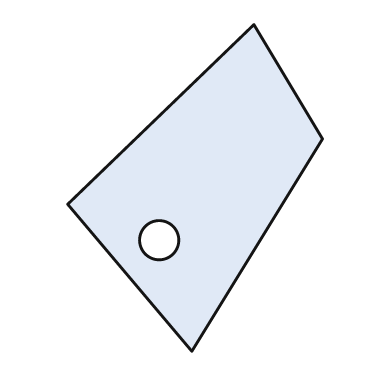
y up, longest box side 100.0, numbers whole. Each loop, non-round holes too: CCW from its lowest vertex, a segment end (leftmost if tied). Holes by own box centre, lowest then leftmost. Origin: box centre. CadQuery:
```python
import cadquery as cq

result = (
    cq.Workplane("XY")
    .moveTo(-1.0, -50.0)
    .lineTo(39.0, 15.0)
    .lineTo(18.0, 50.0)
    .lineTo(-39.0, -5.0)
    .close()
    .moveTo(-11.0, -16.0)
    .circle(6.0)
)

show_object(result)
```